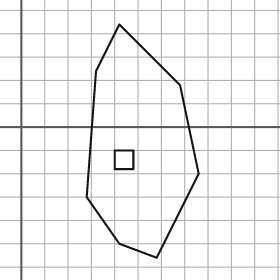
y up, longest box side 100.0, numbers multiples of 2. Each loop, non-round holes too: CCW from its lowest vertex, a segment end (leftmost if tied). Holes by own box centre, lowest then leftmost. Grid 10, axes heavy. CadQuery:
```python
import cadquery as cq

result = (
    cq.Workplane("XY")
    .moveTo(58.0, -56.0)
    .lineTo(76.0, -20.0)
    .lineTo(68.0, 18.0)
    .lineTo(42.0, 44.0)
    .lineTo(32.0, 24.0)
    .lineTo(28.0, -30.0)
    .lineTo(42.0, -50.0)
    .close()
    .moveTo(40.0, -18.0)
    .lineTo(48.0, -18.0)
    .lineTo(48.0, -10.0)
    .lineTo(40.0, -10.0)
    .close()
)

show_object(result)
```